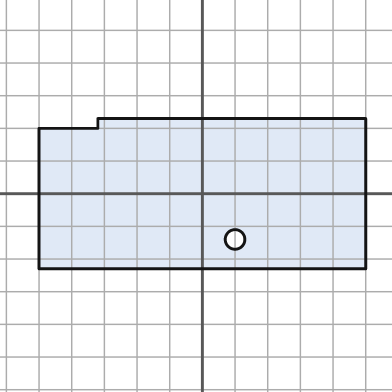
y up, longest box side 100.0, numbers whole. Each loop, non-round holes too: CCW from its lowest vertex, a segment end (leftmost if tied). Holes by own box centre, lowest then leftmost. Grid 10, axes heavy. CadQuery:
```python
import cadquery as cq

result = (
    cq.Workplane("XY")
    .moveTo(-50.0, -23.0)
    .lineTo(50.0, -23.0)
    .lineTo(50.0, 23.0)
    .lineTo(-32.0, 23.0)
    .lineTo(-32.0, 20.0)
    .lineTo(-50.0, 20.0)
    .close()
    .moveTo(10.0, -14.0)
    .circle(3.0)
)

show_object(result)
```